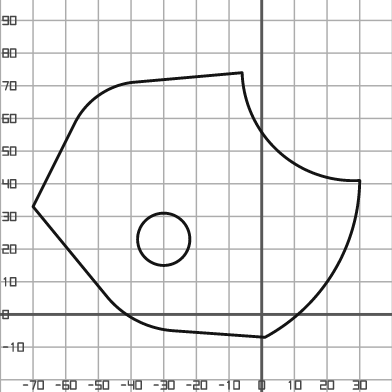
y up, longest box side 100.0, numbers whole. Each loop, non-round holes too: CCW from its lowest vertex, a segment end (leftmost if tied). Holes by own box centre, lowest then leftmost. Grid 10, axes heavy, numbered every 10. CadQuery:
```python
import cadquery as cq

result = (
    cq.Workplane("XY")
    .moveTo(1.0, -7.0)
    .threePointArc((22.0, 13.0), (30.0, 41.0))
    .threePointArc((5.0, 50.0), (-6.0, 74.0))
    .lineTo(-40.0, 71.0)
    .threePointArc((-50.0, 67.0), (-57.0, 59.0))
    .lineTo(-70.0, 33.0)
    .lineTo(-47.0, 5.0)
    .threePointArc((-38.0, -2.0), (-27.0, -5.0))
    .close()
    .moveTo(-30.0, 23.0)
    .circle(8.0)
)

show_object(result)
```